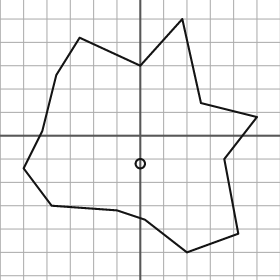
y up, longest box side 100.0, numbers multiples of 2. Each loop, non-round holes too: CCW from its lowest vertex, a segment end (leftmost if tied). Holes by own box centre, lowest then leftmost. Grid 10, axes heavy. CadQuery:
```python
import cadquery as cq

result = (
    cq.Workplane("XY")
    .moveTo(20.0, -50.0)
    .lineTo(42.0, -42.0)
    .lineTo(36.0, -10.0)
    .lineTo(50.0, 8.0)
    .lineTo(26.0, 14.0)
    .lineTo(18.0, 50.0)
    .lineTo(0.0, 30.0)
    .lineTo(-26.0, 42.0)
    .lineTo(-36.0, 26.0)
    .lineTo(-42.0, 2.0)
    .lineTo(-50.0, -14.0)
    .lineTo(-38.0, -30.0)
    .lineTo(-10.0, -32.0)
    .lineTo(2.0, -36.0)
    .close()
    .moveTo(0.0, -12.0)
    .circle(2.0)
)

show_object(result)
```